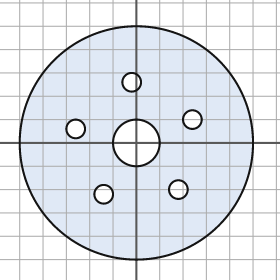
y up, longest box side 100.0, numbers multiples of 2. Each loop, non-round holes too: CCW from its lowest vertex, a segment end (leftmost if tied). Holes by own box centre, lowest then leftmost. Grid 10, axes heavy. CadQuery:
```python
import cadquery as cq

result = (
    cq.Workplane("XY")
    .moveTo(0.0, 0.0)
    .circle(50.0)
    .moveTo(-14.0, -22.0)
    .circle(4.0)
    .moveTo(18.0, -20.0)
    .circle(4.0)
    .moveTo(0.0, 0.0)
    .circle(10.0)
    .moveTo(-26.0, 6.0)
    .circle(4.0)
    .moveTo(24.0, 10.0)
    .circle(4.0)
    .moveTo(-2.0, 26.0)
    .circle(4.0)
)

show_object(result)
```